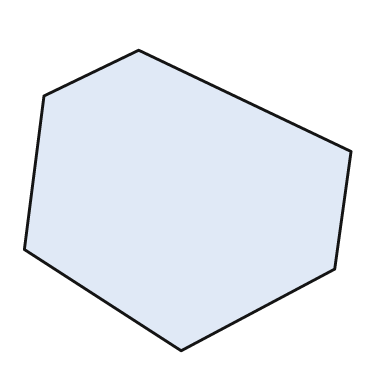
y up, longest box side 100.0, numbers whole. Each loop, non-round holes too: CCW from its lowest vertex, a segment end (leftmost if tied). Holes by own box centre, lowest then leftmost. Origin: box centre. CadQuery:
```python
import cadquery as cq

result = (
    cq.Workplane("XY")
    .moveTo(-2.0, -46.0)
    .lineTo(45.0, -21.0)
    .lineTo(50.0, 15.0)
    .lineTo(-15.0, 46.0)
    .lineTo(-44.0, 32.0)
    .lineTo(-50.0, -15.0)
    .close()
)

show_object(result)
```